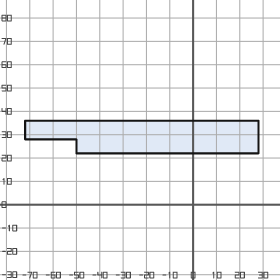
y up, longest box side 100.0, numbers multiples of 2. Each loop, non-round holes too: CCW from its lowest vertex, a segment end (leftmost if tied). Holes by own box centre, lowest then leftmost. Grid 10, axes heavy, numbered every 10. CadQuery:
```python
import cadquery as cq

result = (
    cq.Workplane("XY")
    .moveTo(-50.0, 22.0)
    .lineTo(28.0, 22.0)
    .lineTo(28.0, 36.0)
    .lineTo(-72.0, 36.0)
    .lineTo(-72.0, 28.0)
    .lineTo(-50.0, 28.0)
    .close()
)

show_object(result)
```